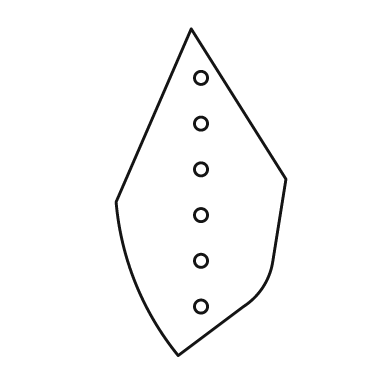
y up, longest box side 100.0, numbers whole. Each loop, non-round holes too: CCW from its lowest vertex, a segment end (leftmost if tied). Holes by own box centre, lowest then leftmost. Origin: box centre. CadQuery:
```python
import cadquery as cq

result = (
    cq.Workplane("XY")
    .moveTo(-7.0, -50.0)
    .lineTo(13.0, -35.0)
    .threePointArc((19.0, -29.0), (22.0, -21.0))
    .lineTo(26.0, 4.0)
    .lineTo(-3.0, 50.0)
    .lineTo(-26.0, -3.0)
    .threePointArc((-20.0, -28.0), (-7.0, -50.0))
    .close()
    .moveTo(0.0, -35.0)
    .circle(2.0)
    .moveTo(0.0, -21.0)
    .circle(2.0)
    .moveTo(0.0, -7.0)
    .circle(2.0)
    .moveTo(0.0, 7.0)
    .circle(2.0)
    .moveTo(0.0, 21.0)
    .circle(2.0)
    .moveTo(0.0, 35.0)
    .circle(2.0)
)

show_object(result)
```